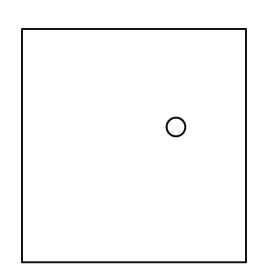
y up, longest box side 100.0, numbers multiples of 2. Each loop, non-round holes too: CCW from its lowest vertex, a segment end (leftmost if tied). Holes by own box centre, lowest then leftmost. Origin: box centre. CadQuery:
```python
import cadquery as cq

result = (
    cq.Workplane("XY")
    .moveTo(-48.0, -50.0)
    .lineTo(48.0, -50.0)
    .lineTo(48.0, 50.0)
    .lineTo(-48.0, 50.0)
    .close()
    .moveTo(18.0, 8.0)
    .circle(4.0)
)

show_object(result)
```